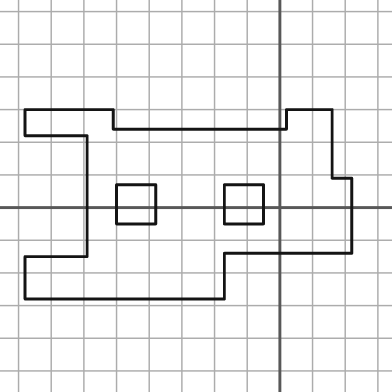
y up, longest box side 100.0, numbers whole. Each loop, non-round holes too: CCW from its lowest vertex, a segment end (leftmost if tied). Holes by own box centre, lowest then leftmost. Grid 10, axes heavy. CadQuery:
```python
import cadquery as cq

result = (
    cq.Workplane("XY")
    .moveTo(-78.0, -28.0)
    .lineTo(-17.0, -28.0)
    .lineTo(-17.0, -14.0)
    .lineTo(22.0, -14.0)
    .lineTo(22.0, 9.0)
    .lineTo(16.0, 9.0)
    .lineTo(16.0, 30.0)
    .lineTo(2.0, 30.0)
    .lineTo(2.0, 24.0)
    .lineTo(-51.0, 24.0)
    .lineTo(-51.0, 30.0)
    .lineTo(-78.0, 30.0)
    .lineTo(-78.0, 22.0)
    .lineTo(-59.0, 22.0)
    .lineTo(-59.0, -15.0)
    .lineTo(-78.0, -15.0)
    .close()
    .moveTo(-50.0, -5.0)
    .lineTo(-38.0, -5.0)
    .lineTo(-38.0, 7.0)
    .lineTo(-50.0, 7.0)
    .close()
    .moveTo(-17.0, -5.0)
    .lineTo(-5.0, -5.0)
    .lineTo(-5.0, 7.0)
    .lineTo(-17.0, 7.0)
    .close()
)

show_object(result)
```